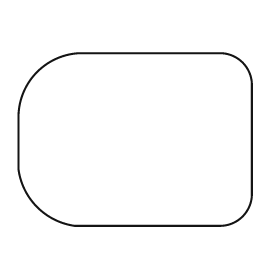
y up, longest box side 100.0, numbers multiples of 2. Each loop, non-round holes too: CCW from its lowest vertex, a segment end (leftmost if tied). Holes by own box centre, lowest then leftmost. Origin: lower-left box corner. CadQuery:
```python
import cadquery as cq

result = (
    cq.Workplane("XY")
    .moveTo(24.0, 0.0)
    .lineTo(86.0, 0.0)
    .threePointArc((96.0, 4.0), (100.0, 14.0))
    .lineTo(100.0, 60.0)
    .threePointArc((96.0, 70.0), (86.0, 74.0))
    .lineTo(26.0, 74.0)
    .threePointArc((8.0, 66.0), (0.0, 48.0))
    .lineTo(0.0, 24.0)
    .threePointArc((8.0, 8.0), (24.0, 0.0))
    .close()
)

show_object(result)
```